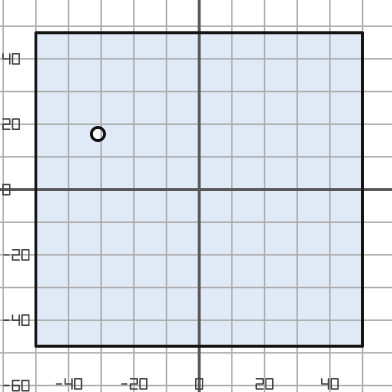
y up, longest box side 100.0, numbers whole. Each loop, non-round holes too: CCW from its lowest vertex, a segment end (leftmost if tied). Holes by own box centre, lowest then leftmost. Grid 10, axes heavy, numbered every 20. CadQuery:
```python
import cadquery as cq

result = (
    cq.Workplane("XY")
    .moveTo(-50.0, -48.0)
    .lineTo(50.0, -48.0)
    .lineTo(50.0, 48.0)
    .lineTo(-50.0, 48.0)
    .close()
    .moveTo(-31.0, 17.0)
    .circle(2.0)
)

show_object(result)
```